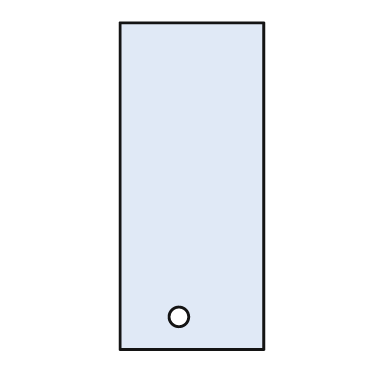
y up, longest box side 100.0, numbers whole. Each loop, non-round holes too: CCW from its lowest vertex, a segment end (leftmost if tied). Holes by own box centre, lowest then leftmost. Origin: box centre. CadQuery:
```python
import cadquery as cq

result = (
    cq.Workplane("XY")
    .moveTo(-22.0, -50.0)
    .lineTo(22.0, -50.0)
    .lineTo(22.0, 50.0)
    .lineTo(-22.0, 50.0)
    .close()
    .moveTo(-4.0, -40.0)
    .circle(3.0)
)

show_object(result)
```